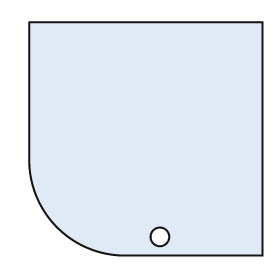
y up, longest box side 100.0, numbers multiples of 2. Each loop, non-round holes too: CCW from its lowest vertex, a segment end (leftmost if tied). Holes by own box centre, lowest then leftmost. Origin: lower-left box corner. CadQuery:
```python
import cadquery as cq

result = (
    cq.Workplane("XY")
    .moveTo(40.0, 0.0)
    .lineTo(100.0, 0.0)
    .lineTo(100.0, 100.0)
    .lineTo(0.0, 100.0)
    .lineTo(0.0, 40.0)
    .threePointArc((12.0, 12.0), (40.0, 0.0))
    .close()
    .moveTo(56.0, 8.0)
    .circle(4.0)
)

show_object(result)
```